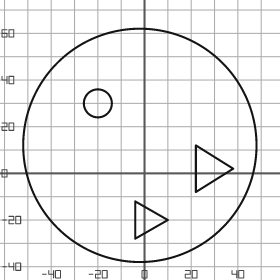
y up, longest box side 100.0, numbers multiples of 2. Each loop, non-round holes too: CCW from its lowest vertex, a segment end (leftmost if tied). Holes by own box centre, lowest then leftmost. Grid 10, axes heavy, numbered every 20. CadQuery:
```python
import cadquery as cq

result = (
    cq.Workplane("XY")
    .moveTo(-2.0, 12.0)
    .circle(50.0)
    .moveTo(-4.0, -28.0)
    .lineTo(10.0, -20.0)
    .lineTo(-4.0, -12.0)
    .close()
    .moveTo(22.0, -8.0)
    .lineTo(38.0, 2.0)
    .lineTo(22.0, 12.0)
    .close()
    .moveTo(-20.0, 30.0)
    .circle(6.0)
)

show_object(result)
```